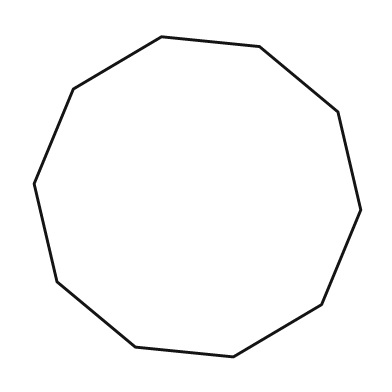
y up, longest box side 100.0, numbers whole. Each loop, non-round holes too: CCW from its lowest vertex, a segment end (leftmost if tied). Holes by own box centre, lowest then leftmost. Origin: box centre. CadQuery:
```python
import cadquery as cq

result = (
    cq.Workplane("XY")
    .moveTo(11.0, -49.0)
    .lineTo(38.0, -33.0)
    .lineTo(50.0, -4.0)
    .lineTo(43.0, 26.0)
    .lineTo(19.0, 46.0)
    .lineTo(-11.0, 49.0)
    .lineTo(-38.0, 33.0)
    .lineTo(-50.0, 4.0)
    .lineTo(-43.0, -26.0)
    .lineTo(-19.0, -46.0)
    .close()
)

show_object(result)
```